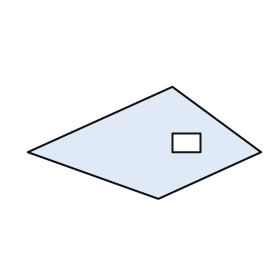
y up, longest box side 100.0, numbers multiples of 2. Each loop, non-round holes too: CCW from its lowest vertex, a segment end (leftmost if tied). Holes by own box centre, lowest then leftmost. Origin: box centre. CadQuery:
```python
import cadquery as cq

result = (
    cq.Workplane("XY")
    .moveTo(6.0, -24.0)
    .lineTo(50.0, -4.0)
    .lineTo(12.0, 24.0)
    .lineTo(-50.0, -4.0)
    .close()
    .moveTo(12.0, -4.0)
    .lineTo(24.0, -4.0)
    .lineTo(24.0, 4.0)
    .lineTo(12.0, 4.0)
    .close()
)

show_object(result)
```